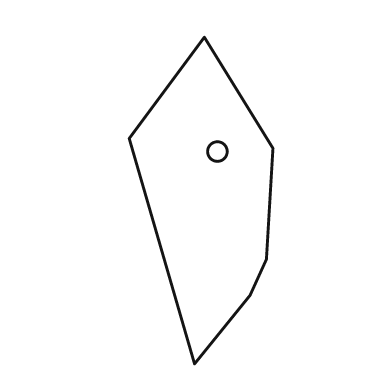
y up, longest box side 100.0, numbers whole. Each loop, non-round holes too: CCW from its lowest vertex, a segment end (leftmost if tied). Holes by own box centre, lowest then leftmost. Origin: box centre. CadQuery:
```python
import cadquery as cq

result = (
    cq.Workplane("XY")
    .moveTo(-2.0, -50.0)
    .lineTo(15.0, -29.0)
    .lineTo(20.0, -18.0)
    .lineTo(22.0, 16.0)
    .lineTo(1.0, 50.0)
    .lineTo(-22.0, 19.0)
    .close()
    .moveTo(5.0, 15.0)
    .circle(3.0)
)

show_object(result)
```